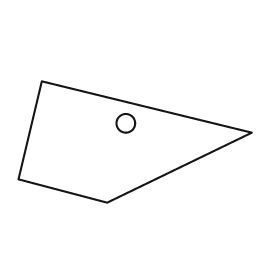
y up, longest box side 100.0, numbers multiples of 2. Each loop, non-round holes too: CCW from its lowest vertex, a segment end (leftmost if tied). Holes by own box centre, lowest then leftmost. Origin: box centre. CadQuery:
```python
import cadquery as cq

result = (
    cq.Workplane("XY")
    .moveTo(-12.0, -26.0)
    .lineTo(50.0, 4.0)
    .lineTo(-40.0, 26.0)
    .lineTo(-50.0, -16.0)
    .close()
    .moveTo(-4.0, 8.0)
    .circle(4.0)
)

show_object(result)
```